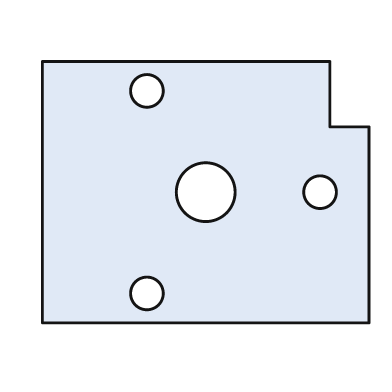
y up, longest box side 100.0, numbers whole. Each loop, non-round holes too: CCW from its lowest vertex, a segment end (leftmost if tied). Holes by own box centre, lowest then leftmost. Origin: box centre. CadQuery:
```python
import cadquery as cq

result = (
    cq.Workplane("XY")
    .moveTo(-50.0, -40.0)
    .lineTo(50.0, -40.0)
    .lineTo(50.0, 20.0)
    .lineTo(38.0, 20.0)
    .lineTo(38.0, 40.0)
    .lineTo(-50.0, 40.0)
    .close()
    .moveTo(-18.0, -31.0)
    .circle(5.0)
    .moveTo(0.0, 0.0)
    .circle(9.0)
    .moveTo(35.0, 0.0)
    .circle(5.0)
    .moveTo(-18.0, 31.0)
    .circle(5.0)
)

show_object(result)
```